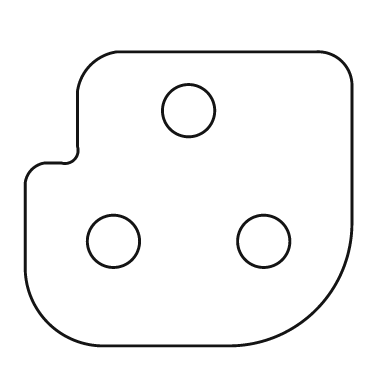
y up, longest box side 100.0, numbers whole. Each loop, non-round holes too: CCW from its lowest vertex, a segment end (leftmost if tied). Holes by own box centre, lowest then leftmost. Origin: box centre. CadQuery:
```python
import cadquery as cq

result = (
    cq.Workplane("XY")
    .moveTo(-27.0, -45.0)
    .lineTo(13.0, -45.0)
    .threePointArc((39.0, -34.0), (50.0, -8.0))
    .lineTo(50.0, 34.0)
    .threePointArc((47.0, 42.0), (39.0, 45.0))
    .lineTo(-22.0, 45.0)
    .threePointArc((-30.0, 41.0), (-34.0, 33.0))
    .lineTo(-34.0, 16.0)
    .threePointArc((-35.0, 12.0), (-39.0, 11.0))
    .lineTo(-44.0, 11.0)
    .threePointArc((-48.0, 9.0), (-50.0, 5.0))
    .lineTo(-50.0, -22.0)
    .threePointArc((-43.0, -38.0), (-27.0, -45.0))
    .close()
    .moveTo(-23.0, -13.0)
    .circle(8.0)
    .moveTo(23.0, -13.0)
    .circle(8.0)
    .moveTo(0.0, 27.0)
    .circle(8.0)
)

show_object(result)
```